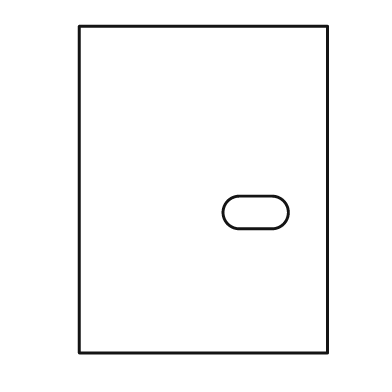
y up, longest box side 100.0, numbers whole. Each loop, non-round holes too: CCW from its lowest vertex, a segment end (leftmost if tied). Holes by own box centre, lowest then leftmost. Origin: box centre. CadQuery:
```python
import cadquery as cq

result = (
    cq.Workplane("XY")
    .moveTo(-38.0, -50.0)
    .lineTo(38.0, -50.0)
    .lineTo(38.0, 50.0)
    .lineTo(-38.0, 50.0)
    .close()
    .moveTo(11.0, -12.0)
    .lineTo(21.0, -12.0)
    .threePointArc((26.0, -7.0), (21.0, -2.0))
    .lineTo(11.0, -2.0)
    .threePointArc((6.0, -7.0), (11.0, -12.0))
    .close()
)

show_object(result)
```